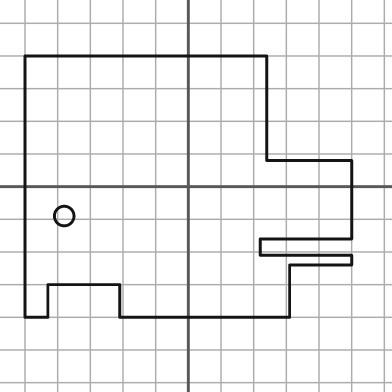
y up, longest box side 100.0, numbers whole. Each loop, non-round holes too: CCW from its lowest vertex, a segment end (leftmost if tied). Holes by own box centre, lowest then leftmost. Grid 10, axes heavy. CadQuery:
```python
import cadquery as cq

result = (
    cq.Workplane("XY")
    .moveTo(-50.0, -40.0)
    .lineTo(-43.0, -40.0)
    .lineTo(-43.0, -30.0)
    .lineTo(-21.0, -30.0)
    .lineTo(-21.0, -40.0)
    .lineTo(31.0, -40.0)
    .lineTo(31.0, -24.0)
    .lineTo(50.0, -24.0)
    .lineTo(50.0, -21.0)
    .lineTo(22.0, -21.0)
    .lineTo(22.0, -16.0)
    .lineTo(50.0, -16.0)
    .lineTo(50.0, 8.0)
    .lineTo(24.0, 8.0)
    .lineTo(24.0, 40.0)
    .lineTo(-50.0, 40.0)
    .close()
    .moveTo(-38.0, -9.0)
    .circle(3.0)
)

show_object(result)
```